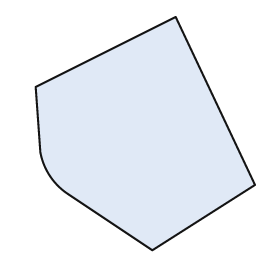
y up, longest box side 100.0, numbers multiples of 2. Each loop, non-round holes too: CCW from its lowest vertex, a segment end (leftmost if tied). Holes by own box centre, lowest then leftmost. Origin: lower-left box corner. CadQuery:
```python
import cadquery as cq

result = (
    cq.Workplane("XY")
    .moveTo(50.0, 0.0)
    .lineTo(94.0, 28.0)
    .lineTo(60.0, 100.0)
    .lineTo(0.0, 70.0)
    .lineTo(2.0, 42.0)
    .threePointArc((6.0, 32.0), (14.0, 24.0))
    .close()
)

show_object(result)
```